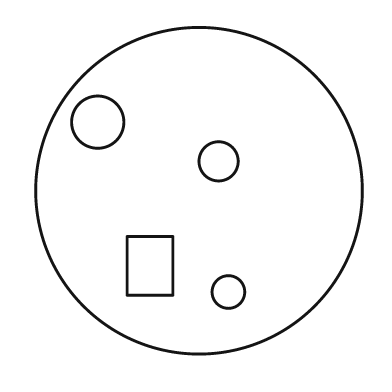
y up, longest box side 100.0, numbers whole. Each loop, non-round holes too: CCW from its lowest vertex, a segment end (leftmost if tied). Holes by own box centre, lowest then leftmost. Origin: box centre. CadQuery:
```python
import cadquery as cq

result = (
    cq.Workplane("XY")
    .moveTo(0.0, 0.0)
    .circle(50.0)
    .moveTo(9.0, -31.0)
    .circle(5.0)
    .moveTo(-22.0, -32.0)
    .lineTo(-8.0, -32.0)
    .lineTo(-8.0, -14.0)
    .lineTo(-22.0, -14.0)
    .close()
    .moveTo(6.0, 9.0)
    .circle(6.0)
    .moveTo(-31.0, 21.0)
    .circle(8.0)
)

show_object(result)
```